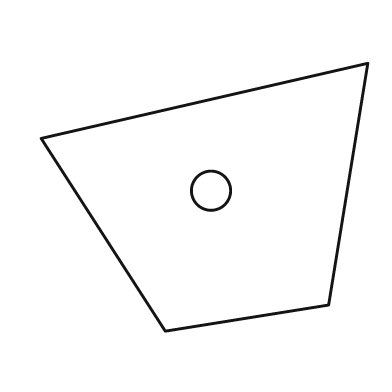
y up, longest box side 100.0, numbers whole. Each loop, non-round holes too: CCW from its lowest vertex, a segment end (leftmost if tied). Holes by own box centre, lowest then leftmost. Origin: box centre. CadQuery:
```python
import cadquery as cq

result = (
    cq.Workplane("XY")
    .moveTo(-12.0, -41.0)
    .lineTo(38.0, -33.0)
    .lineTo(50.0, 41.0)
    .lineTo(-50.0, 18.0)
    .close()
    .moveTo(2.0, 2.0)
    .circle(6.0)
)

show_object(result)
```